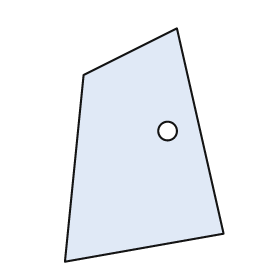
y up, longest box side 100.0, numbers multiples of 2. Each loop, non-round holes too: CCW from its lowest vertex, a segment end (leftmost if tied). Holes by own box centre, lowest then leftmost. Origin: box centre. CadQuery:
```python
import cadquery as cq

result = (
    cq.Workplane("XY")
    .moveTo(-34.0, -50.0)
    .lineTo(34.0, -38.0)
    .lineTo(14.0, 50.0)
    .lineTo(-26.0, 30.0)
    .close()
    .moveTo(10.0, 6.0)
    .circle(4.0)
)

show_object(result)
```